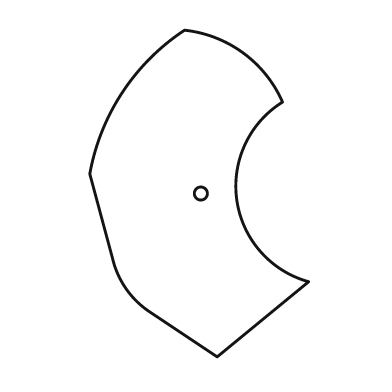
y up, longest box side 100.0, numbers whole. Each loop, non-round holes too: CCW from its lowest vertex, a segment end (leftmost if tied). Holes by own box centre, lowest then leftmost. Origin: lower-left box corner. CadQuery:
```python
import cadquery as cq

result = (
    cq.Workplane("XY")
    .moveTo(39.0, 0.0)
    .lineTo(67.0, 23.0)
    .threePointArc((45.0, 48.0), (59.0, 78.0))
    .threePointArc((47.0, 93.0), (29.0, 100.0))
    .threePointArc((10.0, 81.0), (0.0, 56.0))
    .lineTo(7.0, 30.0)
    .threePointArc((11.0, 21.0), (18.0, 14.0))
    .close()
    .moveTo(34.0, 50.0)
    .circle(2.0)
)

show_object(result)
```